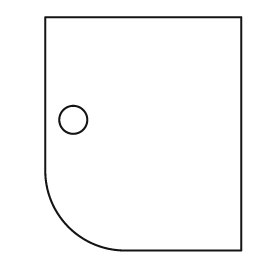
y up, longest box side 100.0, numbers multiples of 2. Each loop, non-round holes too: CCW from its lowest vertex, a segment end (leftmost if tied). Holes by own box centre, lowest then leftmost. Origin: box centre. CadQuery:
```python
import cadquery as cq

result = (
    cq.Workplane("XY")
    .moveTo(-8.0, -50.0)
    .lineTo(42.0, -50.0)
    .lineTo(42.0, 50.0)
    .lineTo(-42.0, 50.0)
    .lineTo(-42.0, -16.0)
    .threePointArc((-32.0, -40.0), (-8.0, -50.0))
    .close()
    .moveTo(-30.0, 6.0)
    .circle(6.0)
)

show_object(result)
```